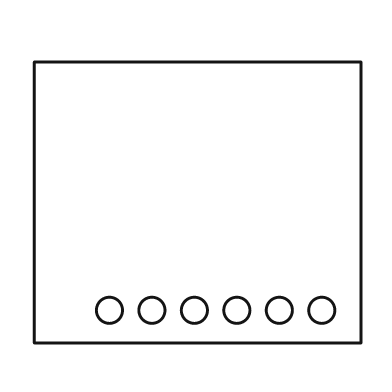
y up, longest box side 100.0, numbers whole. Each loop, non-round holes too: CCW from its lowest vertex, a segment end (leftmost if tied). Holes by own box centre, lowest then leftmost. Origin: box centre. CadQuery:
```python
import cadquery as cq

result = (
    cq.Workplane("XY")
    .moveTo(-50.0, -43.0)
    .lineTo(50.0, -43.0)
    .lineTo(50.0, 43.0)
    .lineTo(-50.0, 43.0)
    .close()
    .moveTo(-27.0, -33.0)
    .circle(4.0)
    .moveTo(-14.0, -33.0)
    .circle(4.0)
    .moveTo(-1.0, -33.0)
    .circle(4.0)
    .moveTo(12.0, -33.0)
    .circle(4.0)
    .moveTo(25.0, -33.0)
    .circle(4.0)
    .moveTo(38.0, -33.0)
    .circle(4.0)
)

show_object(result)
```